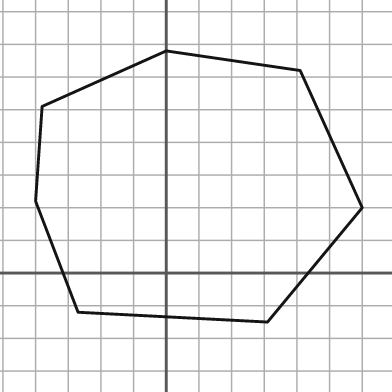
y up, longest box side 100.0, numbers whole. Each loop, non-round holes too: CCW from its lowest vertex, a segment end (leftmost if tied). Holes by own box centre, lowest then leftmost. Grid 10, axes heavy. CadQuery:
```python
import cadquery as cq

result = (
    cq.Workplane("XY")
    .moveTo(31.0, -15.0)
    .lineTo(60.0, 20.0)
    .lineTo(41.0, 62.0)
    .lineTo(0.0, 68.0)
    .lineTo(-38.0, 51.0)
    .lineTo(-40.0, 22.0)
    .lineTo(-27.0, -12.0)
    .close()
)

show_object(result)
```